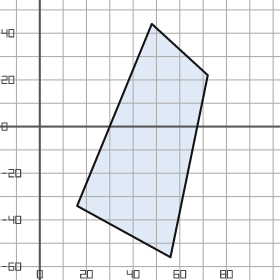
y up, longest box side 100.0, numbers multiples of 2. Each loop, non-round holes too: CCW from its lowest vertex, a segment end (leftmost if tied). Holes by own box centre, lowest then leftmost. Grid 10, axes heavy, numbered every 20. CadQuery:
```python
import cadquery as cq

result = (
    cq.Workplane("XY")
    .moveTo(56.0, -56.0)
    .lineTo(72.0, 22.0)
    .lineTo(48.0, 44.0)
    .lineTo(16.0, -34.0)
    .close()
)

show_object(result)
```